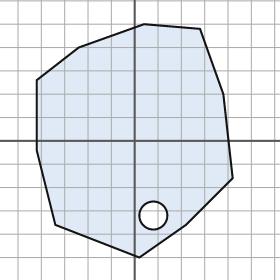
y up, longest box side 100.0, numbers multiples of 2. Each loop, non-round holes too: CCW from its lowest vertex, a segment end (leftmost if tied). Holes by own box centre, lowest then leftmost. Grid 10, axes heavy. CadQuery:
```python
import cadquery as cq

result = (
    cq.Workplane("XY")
    .moveTo(2.0, -50.0)
    .lineTo(22.0, -36.0)
    .lineTo(42.0, -16.0)
    .lineTo(38.0, 20.0)
    .lineTo(28.0, 48.0)
    .lineTo(4.0, 50.0)
    .lineTo(-24.0, 40.0)
    .lineTo(-42.0, 26.0)
    .lineTo(-42.0, -4.0)
    .lineTo(-34.0, -36.0)
    .close()
    .moveTo(8.0, -32.0)
    .circle(6.0)
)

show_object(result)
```